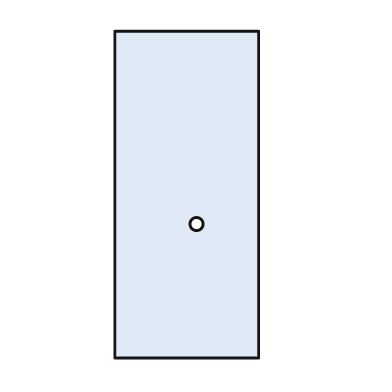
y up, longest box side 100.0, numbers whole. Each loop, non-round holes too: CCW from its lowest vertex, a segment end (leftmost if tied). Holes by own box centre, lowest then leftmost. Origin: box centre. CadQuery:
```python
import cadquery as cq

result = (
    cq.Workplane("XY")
    .moveTo(-22.0, -50.0)
    .lineTo(22.0, -50.0)
    .lineTo(22.0, 50.0)
    .lineTo(-22.0, 50.0)
    .close()
    .moveTo(3.0, -9.0)
    .circle(2.0)
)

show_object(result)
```